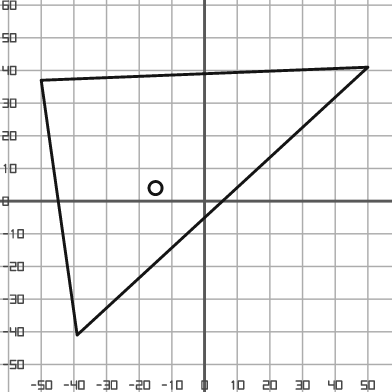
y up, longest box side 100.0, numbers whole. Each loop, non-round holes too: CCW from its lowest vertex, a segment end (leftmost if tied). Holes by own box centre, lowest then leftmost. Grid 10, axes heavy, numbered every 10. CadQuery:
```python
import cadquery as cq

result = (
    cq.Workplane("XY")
    .moveTo(-39.0, -41.0)
    .lineTo(50.0, 41.0)
    .lineTo(-50.0, 37.0)
    .close()
    .moveTo(-15.0, 4.0)
    .circle(2.0)
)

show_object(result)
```